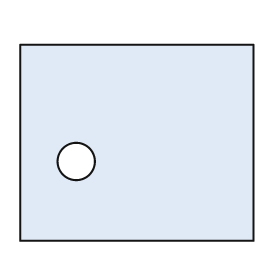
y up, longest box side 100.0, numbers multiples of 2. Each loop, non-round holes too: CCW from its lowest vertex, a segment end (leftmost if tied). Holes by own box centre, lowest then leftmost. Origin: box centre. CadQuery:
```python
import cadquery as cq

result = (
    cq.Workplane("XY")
    .moveTo(-50.0, -42.0)
    .lineTo(50.0, -42.0)
    .lineTo(50.0, 42.0)
    .lineTo(-50.0, 42.0)
    .close()
    .moveTo(-26.0, -8.0)
    .circle(8.0)
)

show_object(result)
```